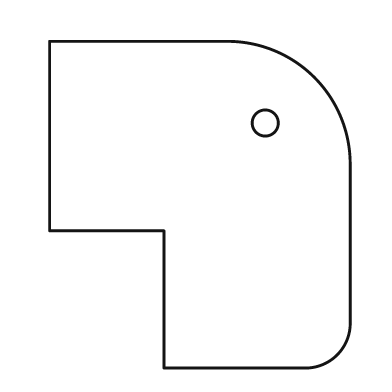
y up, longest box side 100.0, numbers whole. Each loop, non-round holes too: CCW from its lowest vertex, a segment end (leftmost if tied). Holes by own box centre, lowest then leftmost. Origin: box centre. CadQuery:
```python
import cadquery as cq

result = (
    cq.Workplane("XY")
    .moveTo(-11.0, -50.0)
    .lineTo(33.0, -50.0)
    .threePointArc((42.0, -46.0), (46.0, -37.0))
    .lineTo(46.0, 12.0)
    .threePointArc((35.0, 39.0), (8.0, 50.0))
    .lineTo(-46.0, 50.0)
    .lineTo(-46.0, -8.0)
    .lineTo(-11.0, -8.0)
    .close()
    .moveTo(20.0, 25.0)
    .circle(4.0)
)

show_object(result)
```